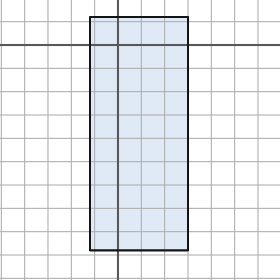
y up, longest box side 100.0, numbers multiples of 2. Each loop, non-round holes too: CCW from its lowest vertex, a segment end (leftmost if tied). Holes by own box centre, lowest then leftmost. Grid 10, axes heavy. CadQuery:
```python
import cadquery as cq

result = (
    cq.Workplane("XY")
    .moveTo(-12.0, -88.0)
    .lineTo(30.0, -88.0)
    .lineTo(30.0, 12.0)
    .lineTo(-12.0, 12.0)
    .close()
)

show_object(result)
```